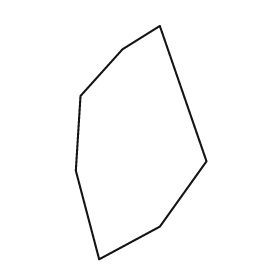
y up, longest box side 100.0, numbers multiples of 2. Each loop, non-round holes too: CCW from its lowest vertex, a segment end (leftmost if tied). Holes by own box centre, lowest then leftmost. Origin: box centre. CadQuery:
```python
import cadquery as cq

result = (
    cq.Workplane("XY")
    .moveTo(-18.0, -50.0)
    .lineTo(8.0, -36.0)
    .lineTo(28.0, -8.0)
    .lineTo(8.0, 50.0)
    .lineTo(-8.0, 40.0)
    .lineTo(-26.0, 20.0)
    .lineTo(-28.0, -12.0)
    .close()
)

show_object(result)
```